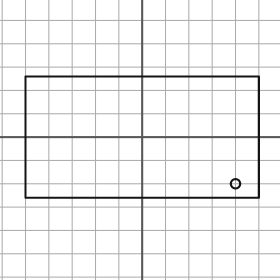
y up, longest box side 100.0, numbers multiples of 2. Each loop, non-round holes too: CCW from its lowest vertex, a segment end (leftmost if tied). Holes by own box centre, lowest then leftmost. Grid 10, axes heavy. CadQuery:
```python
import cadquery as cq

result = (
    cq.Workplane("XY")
    .moveTo(-50.0, -26.0)
    .lineTo(50.0, -26.0)
    .lineTo(50.0, 26.0)
    .lineTo(-50.0, 26.0)
    .close()
    .moveTo(40.0, -20.0)
    .circle(2.0)
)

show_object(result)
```